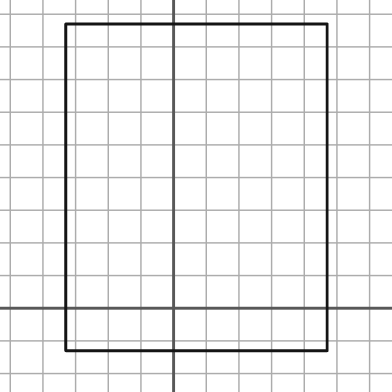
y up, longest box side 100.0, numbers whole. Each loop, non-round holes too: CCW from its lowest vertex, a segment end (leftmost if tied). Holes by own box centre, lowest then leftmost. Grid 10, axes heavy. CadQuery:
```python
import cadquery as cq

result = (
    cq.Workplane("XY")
    .moveTo(-33.0, -13.0)
    .lineTo(47.0, -13.0)
    .lineTo(47.0, 87.0)
    .lineTo(-33.0, 87.0)
    .close()
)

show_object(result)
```